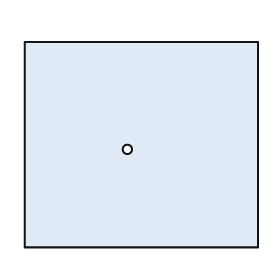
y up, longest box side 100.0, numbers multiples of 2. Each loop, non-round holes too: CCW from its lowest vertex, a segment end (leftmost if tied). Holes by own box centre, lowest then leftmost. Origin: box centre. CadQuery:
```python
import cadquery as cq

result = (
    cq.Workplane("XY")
    .moveTo(-50.0, -44.0)
    .lineTo(50.0, -44.0)
    .lineTo(50.0, 44.0)
    .lineTo(-50.0, 44.0)
    .close()
    .moveTo(-6.0, -2.0)
    .circle(2.0)
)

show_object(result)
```